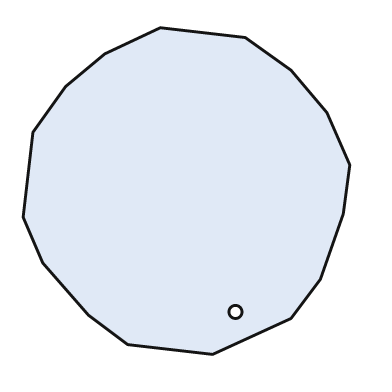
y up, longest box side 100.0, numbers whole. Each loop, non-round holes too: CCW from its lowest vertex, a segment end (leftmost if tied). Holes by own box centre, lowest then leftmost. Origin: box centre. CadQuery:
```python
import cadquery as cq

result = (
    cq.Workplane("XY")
    .moveTo(8.0, -50.0)
    .lineTo(32.0, -39.0)
    .lineTo(41.0, -27.0)
    .lineTo(48.0, -7.0)
    .lineTo(50.0, 8.0)
    .lineTo(43.0, 24.0)
    .lineTo(32.0, 37.0)
    .lineTo(18.0, 47.0)
    .lineTo(-8.0, 50.0)
    .lineTo(-25.0, 42.0)
    .lineTo(-37.0, 32.0)
    .lineTo(-47.0, 18.0)
    .lineTo(-50.0, -8.0)
    .lineTo(-44.0, -22.0)
    .lineTo(-30.0, -38.0)
    .lineTo(-18.0, -47.0)
    .close()
    .moveTo(15.0, -37.0)
    .circle(2.0)
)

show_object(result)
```